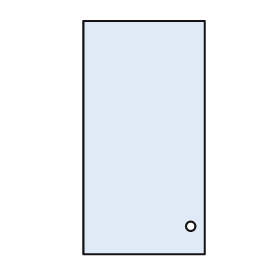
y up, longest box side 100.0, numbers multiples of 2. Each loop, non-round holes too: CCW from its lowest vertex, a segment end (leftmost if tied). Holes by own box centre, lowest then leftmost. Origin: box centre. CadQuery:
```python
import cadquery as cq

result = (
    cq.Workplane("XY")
    .moveTo(-26.0, -50.0)
    .lineTo(26.0, -50.0)
    .lineTo(26.0, 50.0)
    .lineTo(-26.0, 50.0)
    .close()
    .moveTo(20.0, -38.0)
    .circle(2.0)
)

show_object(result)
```